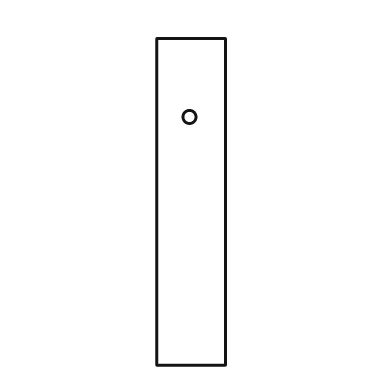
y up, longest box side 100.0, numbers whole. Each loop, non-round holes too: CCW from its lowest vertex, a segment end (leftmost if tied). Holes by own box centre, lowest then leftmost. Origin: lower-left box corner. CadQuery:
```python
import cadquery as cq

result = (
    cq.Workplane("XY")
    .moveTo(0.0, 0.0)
    .lineTo(21.0, 0.0)
    .lineTo(21.0, 100.0)
    .lineTo(0.0, 100.0)
    .close()
    .moveTo(10.0, 76.0)
    .circle(2.0)
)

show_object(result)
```